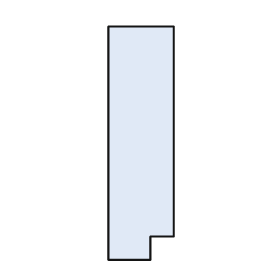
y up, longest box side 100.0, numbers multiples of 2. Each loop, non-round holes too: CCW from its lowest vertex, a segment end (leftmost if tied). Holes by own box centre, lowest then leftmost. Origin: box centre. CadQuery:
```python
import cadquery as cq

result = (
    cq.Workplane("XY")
    .moveTo(-14.0, -50.0)
    .lineTo(4.0, -50.0)
    .lineTo(4.0, -40.0)
    .lineTo(14.0, -40.0)
    .lineTo(14.0, 50.0)
    .lineTo(-14.0, 50.0)
    .close()
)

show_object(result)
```